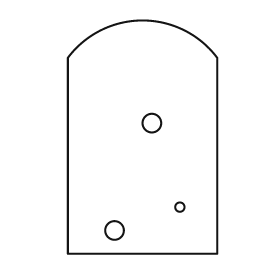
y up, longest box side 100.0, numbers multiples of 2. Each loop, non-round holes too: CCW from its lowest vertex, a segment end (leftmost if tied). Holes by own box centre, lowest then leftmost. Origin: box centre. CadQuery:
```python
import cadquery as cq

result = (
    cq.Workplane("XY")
    .moveTo(-32.0, -50.0)
    .lineTo(32.0, -50.0)
    .lineTo(32.0, 34.0)
    .threePointArc((0.0, 50.0), (-32.0, 34.0))
    .close()
    .moveTo(-12.0, -40.0)
    .circle(4.0)
    .moveTo(16.0, -30.0)
    .circle(2.0)
    .moveTo(4.0, 6.0)
    .circle(4.0)
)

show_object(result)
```